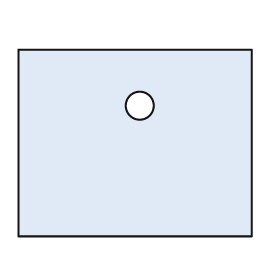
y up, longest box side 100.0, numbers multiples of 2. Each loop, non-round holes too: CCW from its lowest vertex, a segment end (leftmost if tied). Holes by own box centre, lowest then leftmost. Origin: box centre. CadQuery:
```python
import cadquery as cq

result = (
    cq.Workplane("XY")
    .moveTo(-50.0, -40.0)
    .lineTo(50.0, -40.0)
    .lineTo(50.0, 40.0)
    .lineTo(-50.0, 40.0)
    .close()
    .moveTo(2.0, 16.0)
    .circle(6.0)
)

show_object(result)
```